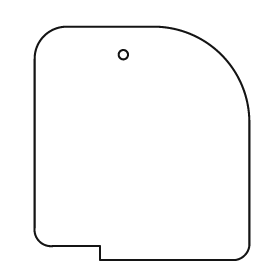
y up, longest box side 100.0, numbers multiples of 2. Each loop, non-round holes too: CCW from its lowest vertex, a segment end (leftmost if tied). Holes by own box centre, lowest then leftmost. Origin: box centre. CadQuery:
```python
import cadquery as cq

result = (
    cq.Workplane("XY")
    .moveTo(-18.0, -50.0)
    .lineTo(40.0, -50.0)
    .threePointArc((44.0, -48.0), (46.0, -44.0))
    .lineTo(46.0, 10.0)
    .threePointArc((34.0, 38.0), (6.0, 50.0))
    .lineTo(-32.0, 50.0)
    .threePointArc((-42.0, 46.0), (-46.0, 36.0))
    .lineTo(-46.0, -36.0)
    .threePointArc((-44.0, -42.0), (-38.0, -44.0))
    .lineTo(-18.0, -44.0)
    .close()
    .moveTo(-8.0, 38.0)
    .circle(2.0)
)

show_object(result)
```